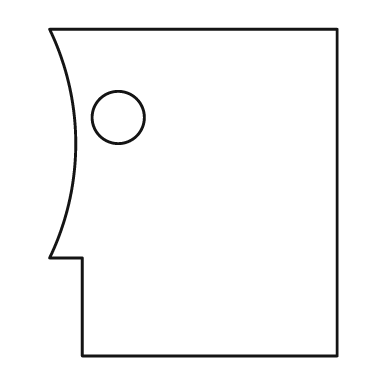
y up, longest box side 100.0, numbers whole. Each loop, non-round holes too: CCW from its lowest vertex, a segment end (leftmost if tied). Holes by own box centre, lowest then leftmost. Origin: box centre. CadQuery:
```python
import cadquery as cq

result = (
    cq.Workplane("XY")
    .moveTo(-34.0, -50.0)
    .lineTo(44.0, -50.0)
    .lineTo(44.0, 50.0)
    .lineTo(-44.0, 50.0)
    .threePointArc((-36.0, 15.0), (-44.0, -20.0))
    .lineTo(-34.0, -20.0)
    .close()
    .moveTo(-23.0, 23.0)
    .circle(8.0)
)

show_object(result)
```